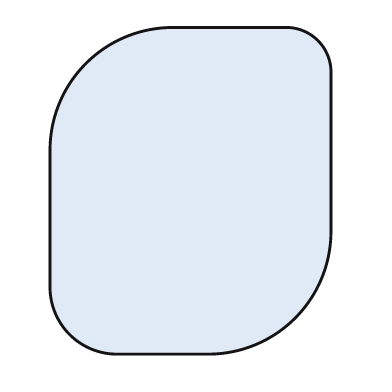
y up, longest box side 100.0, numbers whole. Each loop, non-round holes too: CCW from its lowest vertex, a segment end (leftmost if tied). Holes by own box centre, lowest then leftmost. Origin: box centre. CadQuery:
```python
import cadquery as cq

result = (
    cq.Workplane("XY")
    .moveTo(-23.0, -50.0)
    .lineTo(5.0, -50.0)
    .threePointArc((32.0, -39.0), (43.0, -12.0))
    .lineTo(43.0, 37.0)
    .threePointArc((39.0, 46.0), (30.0, 50.0))
    .lineTo(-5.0, 50.0)
    .threePointArc((-32.0, 39.0), (-43.0, 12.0))
    .lineTo(-43.0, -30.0)
    .threePointArc((-37.0, -44.0), (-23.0, -50.0))
    .close()
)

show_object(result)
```